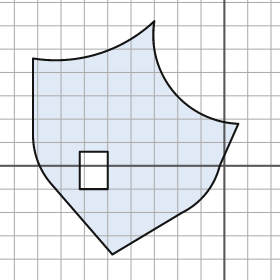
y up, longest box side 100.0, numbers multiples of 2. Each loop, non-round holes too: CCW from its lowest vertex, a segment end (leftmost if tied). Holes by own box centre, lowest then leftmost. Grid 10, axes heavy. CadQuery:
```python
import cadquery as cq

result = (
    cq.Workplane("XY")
    .moveTo(-48.0, -38.0)
    .lineTo(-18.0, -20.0)
    .threePointArc((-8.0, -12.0), (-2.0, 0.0))
    .lineTo(6.0, 18.0)
    .threePointArc((-22.0, 32.0), (-30.0, 62.0))
    .threePointArc((-54.0, 48.0), (-82.0, 46.0))
    .lineTo(-82.0, 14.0)
    .threePointArc((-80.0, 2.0), (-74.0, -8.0))
    .close()
    .moveTo(-62.0, -10.0)
    .lineTo(-50.0, -10.0)
    .lineTo(-50.0, 6.0)
    .lineTo(-62.0, 6.0)
    .close()
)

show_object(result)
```